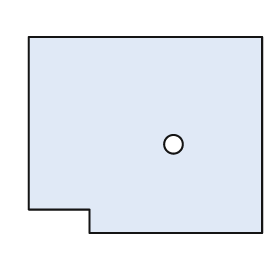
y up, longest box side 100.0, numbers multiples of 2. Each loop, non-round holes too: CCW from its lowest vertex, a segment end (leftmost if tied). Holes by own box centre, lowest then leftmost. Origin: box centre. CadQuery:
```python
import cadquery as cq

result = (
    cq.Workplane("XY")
    .moveTo(-24.0, -42.0)
    .lineTo(50.0, -42.0)
    .lineTo(50.0, 42.0)
    .lineTo(-50.0, 42.0)
    .lineTo(-50.0, -32.0)
    .lineTo(-24.0, -32.0)
    .close()
    .moveTo(12.0, -4.0)
    .circle(4.0)
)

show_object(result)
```